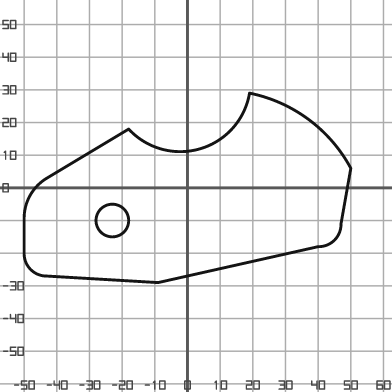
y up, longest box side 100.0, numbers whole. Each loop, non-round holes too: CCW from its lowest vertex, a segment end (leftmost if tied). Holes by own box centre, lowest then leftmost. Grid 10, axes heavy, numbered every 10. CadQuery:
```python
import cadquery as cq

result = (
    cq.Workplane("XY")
    .moveTo(-9.0, -29.0)
    .lineTo(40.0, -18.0)
    .threePointArc((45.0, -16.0), (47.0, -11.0))
    .lineTo(50.0, 6.0)
    .threePointArc((37.0, 21.0), (19.0, 29.0))
    .threePointArc((4.0, 12.0), (-18.0, 18.0))
    .lineTo(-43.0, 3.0)
    .threePointArc((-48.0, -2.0), (-50.0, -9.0))
    .lineTo(-50.0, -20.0)
    .threePointArc((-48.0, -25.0), (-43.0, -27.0))
    .close()
    .moveTo(-23.0, -10.0)
    .circle(5.0)
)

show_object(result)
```